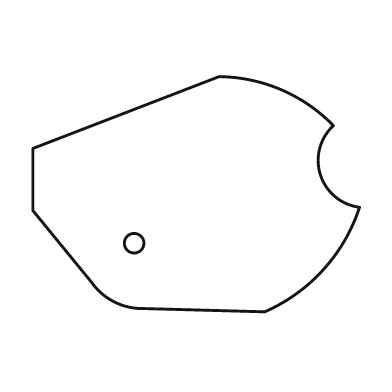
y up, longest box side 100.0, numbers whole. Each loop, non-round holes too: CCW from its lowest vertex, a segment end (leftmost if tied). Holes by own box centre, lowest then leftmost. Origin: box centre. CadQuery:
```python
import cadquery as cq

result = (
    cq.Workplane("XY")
    .moveTo(21.0, -36.0)
    .threePointArc((39.0, -23.0), (50.0, -4.0))
    .threePointArc((38.0, 6.0), (42.0, 21.0))
    .threePointArc((26.0, 32.0), (7.0, 36.0))
    .lineTo(-50.0, 14.0)
    .lineTo(-50.0, -5.0)
    .lineTo(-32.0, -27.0)
    .threePointArc((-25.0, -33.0), (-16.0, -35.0))
    .close()
    .moveTo(-19.0, -15.0)
    .circle(3.0)
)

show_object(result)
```